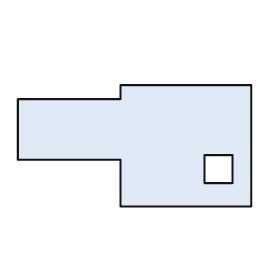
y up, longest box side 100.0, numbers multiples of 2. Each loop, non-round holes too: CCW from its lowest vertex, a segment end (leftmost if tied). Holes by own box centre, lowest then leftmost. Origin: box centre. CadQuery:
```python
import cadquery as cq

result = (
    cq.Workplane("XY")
    .moveTo(-6.0, -26.0)
    .lineTo(50.0, -26.0)
    .lineTo(50.0, 26.0)
    .lineTo(-6.0, 26.0)
    .lineTo(-6.0, 20.0)
    .lineTo(-50.0, 20.0)
    .lineTo(-50.0, -6.0)
    .lineTo(-6.0, -6.0)
    .close()
    .moveTo(30.0, -16.0)
    .lineTo(42.0, -16.0)
    .lineTo(42.0, -4.0)
    .lineTo(30.0, -4.0)
    .close()
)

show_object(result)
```